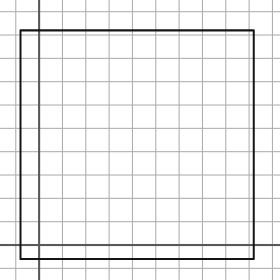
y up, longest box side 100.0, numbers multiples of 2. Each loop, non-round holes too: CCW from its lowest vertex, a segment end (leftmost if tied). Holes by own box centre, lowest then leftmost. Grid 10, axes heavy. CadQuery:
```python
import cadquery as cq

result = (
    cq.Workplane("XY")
    .moveTo(-8.0, -6.0)
    .lineTo(92.0, -6.0)
    .lineTo(92.0, 92.0)
    .lineTo(-8.0, 92.0)
    .close()
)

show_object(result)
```